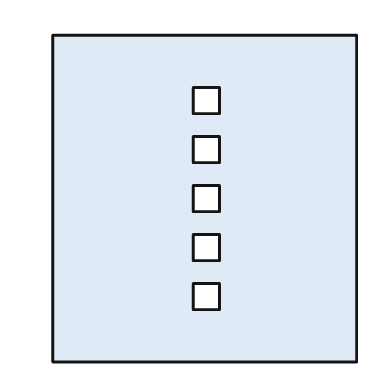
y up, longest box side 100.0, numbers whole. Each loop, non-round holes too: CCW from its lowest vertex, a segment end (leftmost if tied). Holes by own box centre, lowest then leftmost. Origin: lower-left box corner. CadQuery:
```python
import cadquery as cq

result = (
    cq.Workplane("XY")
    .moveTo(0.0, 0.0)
    .lineTo(93.0, 0.0)
    .lineTo(93.0, 100.0)
    .lineTo(0.0, 100.0)
    .close()
    .moveTo(43.0, 16.0)
    .lineTo(51.0, 16.0)
    .lineTo(51.0, 24.0)
    .lineTo(43.0, 24.0)
    .close()
    .moveTo(43.0, 31.0)
    .lineTo(51.0, 31.0)
    .lineTo(51.0, 39.0)
    .lineTo(43.0, 39.0)
    .close()
    .moveTo(43.0, 46.0)
    .lineTo(51.0, 46.0)
    .lineTo(51.0, 54.0)
    .lineTo(43.0, 54.0)
    .close()
    .moveTo(43.0, 61.0)
    .lineTo(51.0, 61.0)
    .lineTo(51.0, 69.0)
    .lineTo(43.0, 69.0)
    .close()
    .moveTo(43.0, 76.0)
    .lineTo(51.0, 76.0)
    .lineTo(51.0, 84.0)
    .lineTo(43.0, 84.0)
    .close()
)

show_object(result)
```